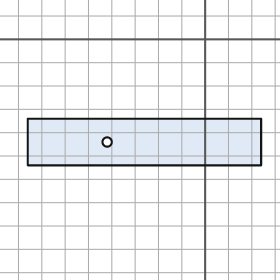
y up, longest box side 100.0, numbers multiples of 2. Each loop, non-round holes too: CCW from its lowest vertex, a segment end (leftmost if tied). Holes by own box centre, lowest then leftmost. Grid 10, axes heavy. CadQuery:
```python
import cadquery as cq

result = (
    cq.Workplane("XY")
    .moveTo(-76.0, -54.0)
    .lineTo(24.0, -54.0)
    .lineTo(24.0, -34.0)
    .lineTo(-76.0, -34.0)
    .close()
    .moveTo(-42.0, -44.0)
    .circle(2.0)
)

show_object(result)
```